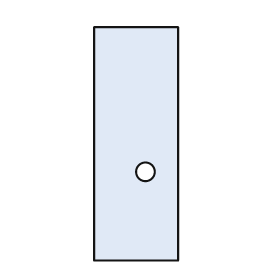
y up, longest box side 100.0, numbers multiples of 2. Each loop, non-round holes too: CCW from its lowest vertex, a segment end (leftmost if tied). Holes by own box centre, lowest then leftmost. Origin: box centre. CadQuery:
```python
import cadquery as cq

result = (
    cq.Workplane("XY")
    .moveTo(-18.0, -50.0)
    .lineTo(18.0, -50.0)
    .lineTo(18.0, 50.0)
    .lineTo(-18.0, 50.0)
    .close()
    .moveTo(4.0, -12.0)
    .circle(4.0)
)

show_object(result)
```